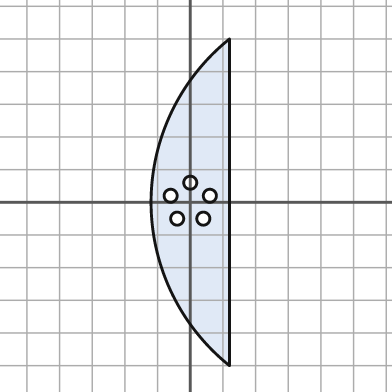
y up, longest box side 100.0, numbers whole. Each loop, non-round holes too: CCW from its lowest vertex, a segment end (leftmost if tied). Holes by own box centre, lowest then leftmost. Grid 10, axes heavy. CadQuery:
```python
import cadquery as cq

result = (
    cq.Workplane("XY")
    .moveTo(12.0, -50.0)
    .lineTo(12.0, 50.0)
    .threePointArc((-12.0, 0.0), (12.0, -50.0))
    .close()
    .moveTo(-4.0, -5.0)
    .circle(2.0)
    .moveTo(4.0, -5.0)
    .circle(2.0)
    .moveTo(-6.0, 2.0)
    .circle(2.0)
    .moveTo(6.0, 2.0)
    .circle(2.0)
    .moveTo(0.0, 6.0)
    .circle(2.0)
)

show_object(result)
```